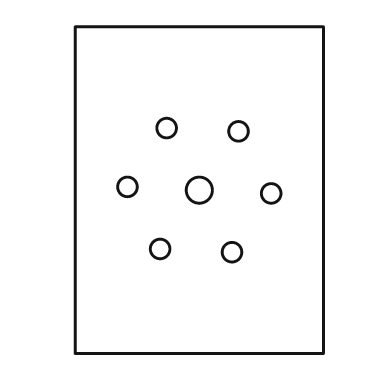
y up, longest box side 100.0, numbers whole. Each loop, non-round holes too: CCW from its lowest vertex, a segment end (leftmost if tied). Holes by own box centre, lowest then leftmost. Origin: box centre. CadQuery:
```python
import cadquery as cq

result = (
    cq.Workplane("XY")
    .moveTo(-38.0, -50.0)
    .lineTo(38.0, -50.0)
    .lineTo(38.0, 50.0)
    .lineTo(-38.0, 50.0)
    .close()
    .moveTo(10.0, -19.0)
    .circle(3.0)
    .moveTo(-12.0, -18.0)
    .circle(3.0)
    .moveTo(22.0, -1.0)
    .circle(3.0)
    .moveTo(0.0, 0.0)
    .circle(4.0)
    .moveTo(-22.0, 1.0)
    .circle(3.0)
    .moveTo(12.0, 18.0)
    .circle(3.0)
    .moveTo(-10.0, 19.0)
    .circle(3.0)
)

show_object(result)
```